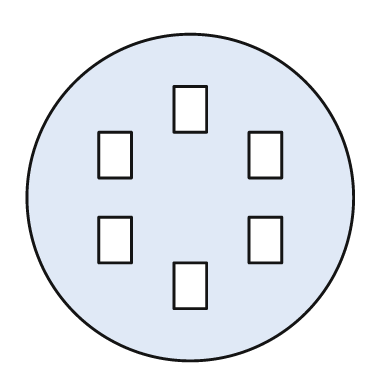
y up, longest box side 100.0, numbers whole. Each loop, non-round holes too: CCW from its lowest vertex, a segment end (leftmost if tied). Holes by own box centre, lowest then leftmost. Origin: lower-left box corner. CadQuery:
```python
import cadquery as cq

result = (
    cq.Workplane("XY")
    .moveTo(50.0, 50.0)
    .circle(50.0)
    .moveTo(45.0, 16.0)
    .lineTo(55.0, 16.0)
    .lineTo(55.0, 30.0)
    .lineTo(45.0, 30.0)
    .close()
    .moveTo(22.0, 30.0)
    .lineTo(32.0, 30.0)
    .lineTo(32.0, 44.0)
    .lineTo(22.0, 44.0)
    .close()
    .moveTo(68.0, 30.0)
    .lineTo(78.0, 30.0)
    .lineTo(78.0, 44.0)
    .lineTo(68.0, 44.0)
    .close()
    .moveTo(22.0, 56.0)
    .lineTo(32.0, 56.0)
    .lineTo(32.0, 70.0)
    .lineTo(22.0, 70.0)
    .close()
    .moveTo(68.0, 56.0)
    .lineTo(78.0, 56.0)
    .lineTo(78.0, 70.0)
    .lineTo(68.0, 70.0)
    .close()
    .moveTo(45.0, 70.0)
    .lineTo(55.0, 70.0)
    .lineTo(55.0, 84.0)
    .lineTo(45.0, 84.0)
    .close()
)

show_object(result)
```